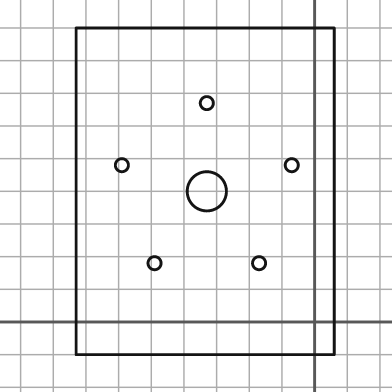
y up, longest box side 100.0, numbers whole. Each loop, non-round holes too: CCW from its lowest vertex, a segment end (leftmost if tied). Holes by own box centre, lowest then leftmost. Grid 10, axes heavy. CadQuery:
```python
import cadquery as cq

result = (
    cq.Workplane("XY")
    .moveTo(-73.0, -10.0)
    .lineTo(6.0, -10.0)
    .lineTo(6.0, 90.0)
    .lineTo(-73.0, 90.0)
    .close()
    .moveTo(-49.0, 18.0)
    .circle(2.0)
    .moveTo(-17.0, 18.0)
    .circle(2.0)
    .moveTo(-33.0, 40.0)
    .circle(6.0)
    .moveTo(-59.0, 48.0)
    .circle(2.0)
    .moveTo(-7.0, 48.0)
    .circle(2.0)
    .moveTo(-33.0, 67.0)
    .circle(2.0)
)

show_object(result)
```